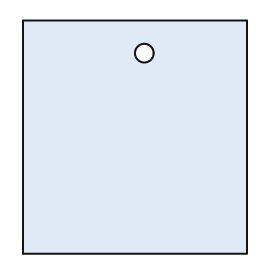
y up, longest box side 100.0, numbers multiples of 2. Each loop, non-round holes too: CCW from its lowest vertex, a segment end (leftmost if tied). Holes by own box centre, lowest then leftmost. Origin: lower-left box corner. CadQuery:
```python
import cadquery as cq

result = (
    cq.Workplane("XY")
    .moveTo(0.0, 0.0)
    .lineTo(96.0, 0.0)
    .lineTo(96.0, 100.0)
    .lineTo(0.0, 100.0)
    .close()
    .moveTo(52.0, 86.0)
    .circle(4.0)
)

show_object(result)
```